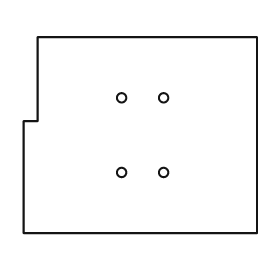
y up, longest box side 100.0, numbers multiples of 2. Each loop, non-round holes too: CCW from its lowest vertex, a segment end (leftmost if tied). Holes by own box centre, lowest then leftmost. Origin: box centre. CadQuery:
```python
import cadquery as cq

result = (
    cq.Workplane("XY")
    .moveTo(-50.0, -42.0)
    .lineTo(50.0, -42.0)
    .lineTo(50.0, 42.0)
    .lineTo(-44.0, 42.0)
    .lineTo(-44.0, 6.0)
    .lineTo(-50.0, 6.0)
    .close()
    .moveTo(-8.0, -16.0)
    .circle(2.0)
    .moveTo(10.0, -16.0)
    .circle(2.0)
    .moveTo(-8.0, 16.0)
    .circle(2.0)
    .moveTo(10.0, 16.0)
    .circle(2.0)
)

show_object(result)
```